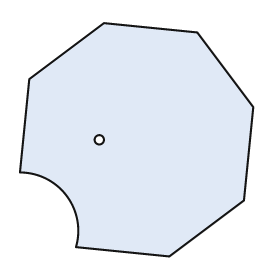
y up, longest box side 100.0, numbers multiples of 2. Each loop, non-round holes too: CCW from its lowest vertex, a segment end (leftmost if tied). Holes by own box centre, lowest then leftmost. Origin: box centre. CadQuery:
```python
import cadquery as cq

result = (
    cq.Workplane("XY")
    .moveTo(14.0, -50.0)
    .lineTo(46.0, -26.0)
    .lineTo(50.0, 14.0)
    .lineTo(26.0, 46.0)
    .lineTo(-14.0, 50.0)
    .lineTo(-46.0, 26.0)
    .lineTo(-50.0, -14.0)
    .threePointArc((-30.0, -24.0), (-26.0, -46.0))
    .close()
    .moveTo(-16.0, 0.0)
    .circle(2.0)
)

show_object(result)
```